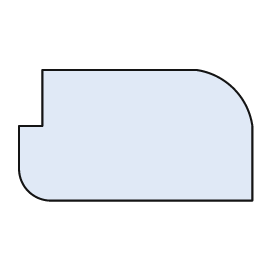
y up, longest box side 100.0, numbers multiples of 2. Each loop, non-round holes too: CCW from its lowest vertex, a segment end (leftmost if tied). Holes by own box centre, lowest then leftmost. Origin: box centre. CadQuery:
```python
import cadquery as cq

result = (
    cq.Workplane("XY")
    .moveTo(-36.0, -28.0)
    .lineTo(50.0, -28.0)
    .lineTo(50.0, 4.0)
    .threePointArc((42.0, 20.0), (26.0, 28.0))
    .lineTo(-40.0, 28.0)
    .lineTo(-40.0, 4.0)
    .lineTo(-50.0, 4.0)
    .lineTo(-50.0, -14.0)
    .threePointArc((-46.0, -24.0), (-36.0, -28.0))
    .close()
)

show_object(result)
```